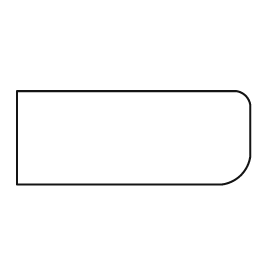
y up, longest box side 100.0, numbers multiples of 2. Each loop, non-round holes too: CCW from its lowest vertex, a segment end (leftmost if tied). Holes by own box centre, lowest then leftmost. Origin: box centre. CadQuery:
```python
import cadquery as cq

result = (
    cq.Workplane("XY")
    .moveTo(-50.0, -20.0)
    .lineTo(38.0, -20.0)
    .threePointArc((46.0, -16.0), (50.0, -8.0))
    .lineTo(50.0, 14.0)
    .threePointArc((48.0, 18.0), (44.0, 20.0))
    .lineTo(-50.0, 20.0)
    .close()
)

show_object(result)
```